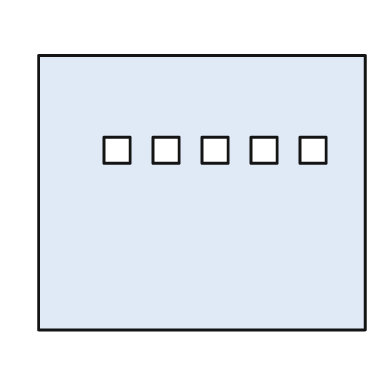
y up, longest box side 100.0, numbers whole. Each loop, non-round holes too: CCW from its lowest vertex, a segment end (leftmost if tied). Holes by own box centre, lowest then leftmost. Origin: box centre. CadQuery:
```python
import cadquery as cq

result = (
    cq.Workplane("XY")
    .moveTo(-50.0, -42.0)
    .lineTo(50.0, -42.0)
    .lineTo(50.0, 42.0)
    .lineTo(-50.0, 42.0)
    .close()
    .moveTo(-30.0, 9.0)
    .lineTo(-22.0, 9.0)
    .lineTo(-22.0, 17.0)
    .lineTo(-30.0, 17.0)
    .close()
    .moveTo(-15.0, 9.0)
    .lineTo(-7.0, 9.0)
    .lineTo(-7.0, 17.0)
    .lineTo(-15.0, 17.0)
    .close()
    .moveTo(0.0, 9.0)
    .lineTo(8.0, 9.0)
    .lineTo(8.0, 17.0)
    .lineTo(0.0, 17.0)
    .close()
    .moveTo(15.0, 9.0)
    .lineTo(23.0, 9.0)
    .lineTo(23.0, 17.0)
    .lineTo(15.0, 17.0)
    .close()
    .moveTo(30.0, 9.0)
    .lineTo(38.0, 9.0)
    .lineTo(38.0, 17.0)
    .lineTo(30.0, 17.0)
    .close()
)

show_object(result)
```